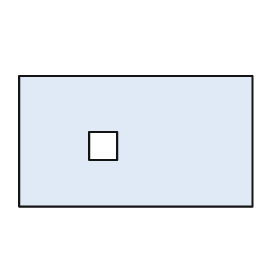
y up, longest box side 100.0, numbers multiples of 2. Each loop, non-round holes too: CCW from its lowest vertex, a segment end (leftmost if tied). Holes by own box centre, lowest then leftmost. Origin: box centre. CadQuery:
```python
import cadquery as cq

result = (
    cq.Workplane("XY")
    .moveTo(-50.0, -28.0)
    .lineTo(50.0, -28.0)
    .lineTo(50.0, 28.0)
    .lineTo(-50.0, 28.0)
    .close()
    .moveTo(-20.0, -8.0)
    .lineTo(-8.0, -8.0)
    .lineTo(-8.0, 4.0)
    .lineTo(-20.0, 4.0)
    .close()
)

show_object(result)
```